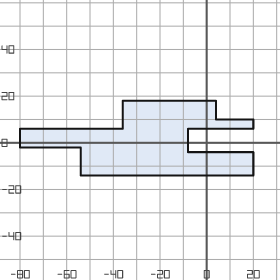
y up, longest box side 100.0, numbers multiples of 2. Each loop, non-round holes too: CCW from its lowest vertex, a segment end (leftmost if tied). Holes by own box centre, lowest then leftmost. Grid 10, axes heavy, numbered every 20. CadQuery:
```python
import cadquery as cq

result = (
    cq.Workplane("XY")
    .moveTo(-54.0, -14.0)
    .lineTo(20.0, -14.0)
    .lineTo(20.0, -4.0)
    .lineTo(-8.0, -4.0)
    .lineTo(-8.0, 6.0)
    .lineTo(20.0, 6.0)
    .lineTo(20.0, 10.0)
    .lineTo(4.0, 10.0)
    .lineTo(4.0, 18.0)
    .lineTo(-36.0, 18.0)
    .lineTo(-36.0, 6.0)
    .lineTo(-80.0, 6.0)
    .lineTo(-80.0, -2.0)
    .lineTo(-54.0, -2.0)
    .close()
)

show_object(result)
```